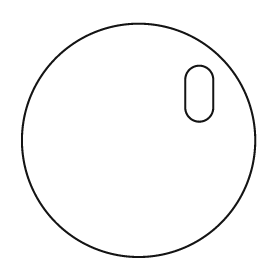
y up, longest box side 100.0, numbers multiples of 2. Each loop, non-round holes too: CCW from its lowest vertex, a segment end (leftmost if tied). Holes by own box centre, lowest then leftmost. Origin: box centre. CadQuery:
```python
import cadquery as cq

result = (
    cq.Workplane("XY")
    .moveTo(0.0, 0.0)
    .circle(50.0)
    .moveTo(20.0, 14.0)
    .threePointArc((26.0, 8.0), (32.0, 14.0))
    .lineTo(32.0, 26.0)
    .threePointArc((26.0, 32.0), (20.0, 26.0))
    .close()
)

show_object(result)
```